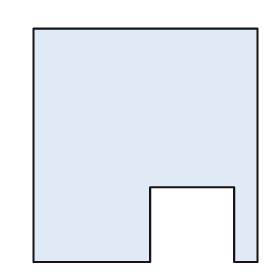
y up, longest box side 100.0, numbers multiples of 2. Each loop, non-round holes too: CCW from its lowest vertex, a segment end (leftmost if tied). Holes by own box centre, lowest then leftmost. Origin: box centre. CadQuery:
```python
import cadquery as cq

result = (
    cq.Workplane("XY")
    .moveTo(-48.0, -50.0)
    .lineTo(2.0, -50.0)
    .lineTo(2.0, -18.0)
    .lineTo(38.0, -18.0)
    .lineTo(38.0, -50.0)
    .lineTo(48.0, -50.0)
    .lineTo(48.0, 50.0)
    .lineTo(-48.0, 50.0)
    .close()
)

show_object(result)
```